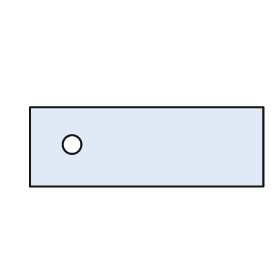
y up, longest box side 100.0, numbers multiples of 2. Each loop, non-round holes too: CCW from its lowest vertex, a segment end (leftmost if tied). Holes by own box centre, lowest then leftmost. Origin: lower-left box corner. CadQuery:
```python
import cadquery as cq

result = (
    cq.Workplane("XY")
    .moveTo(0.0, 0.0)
    .lineTo(100.0, 0.0)
    .lineTo(100.0, 34.0)
    .lineTo(0.0, 34.0)
    .close()
    .moveTo(18.0, 18.0)
    .circle(4.0)
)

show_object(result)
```